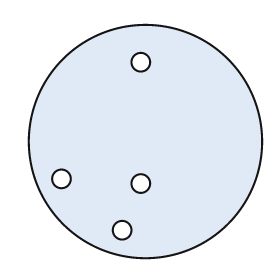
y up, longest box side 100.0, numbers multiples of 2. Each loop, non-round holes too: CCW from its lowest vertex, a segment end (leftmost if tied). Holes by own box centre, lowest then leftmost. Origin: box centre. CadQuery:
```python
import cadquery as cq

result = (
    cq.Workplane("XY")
    .moveTo(0.0, 0.0)
    .circle(50.0)
    .moveTo(-10.0, -38.0)
    .circle(4.0)
    .moveTo(-2.0, -18.0)
    .circle(4.0)
    .moveTo(-36.0, -16.0)
    .circle(4.0)
    .moveTo(-2.0, 34.0)
    .circle(4.0)
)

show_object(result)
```